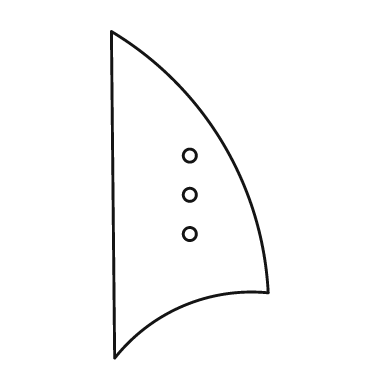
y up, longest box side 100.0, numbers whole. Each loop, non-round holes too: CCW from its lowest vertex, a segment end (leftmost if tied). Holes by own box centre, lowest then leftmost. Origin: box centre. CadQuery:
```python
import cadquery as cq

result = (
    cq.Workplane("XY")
    .moveTo(-23.0, -50.0)
    .threePointArc((-2.0, -34.0), (24.0, -30.0))
    .threePointArc((10.0, 16.0), (-24.0, 50.0))
    .close()
    .moveTo(0.0, -12.0)
    .circle(2.0)
    .moveTo(0.0, 0.0)
    .circle(2.0)
    .moveTo(0.0, 12.0)
    .circle(2.0)
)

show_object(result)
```